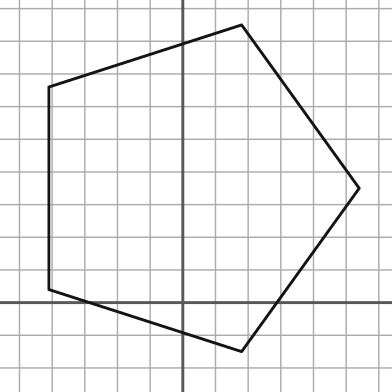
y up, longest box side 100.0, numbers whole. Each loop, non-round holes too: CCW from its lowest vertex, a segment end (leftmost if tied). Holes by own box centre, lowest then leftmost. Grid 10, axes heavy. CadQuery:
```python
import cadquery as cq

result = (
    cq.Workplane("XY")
    .moveTo(18.0, -15.0)
    .lineTo(54.0, 35.0)
    .lineTo(18.0, 85.0)
    .lineTo(-41.0, 66.0)
    .lineTo(-41.0, 4.0)
    .close()
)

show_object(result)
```